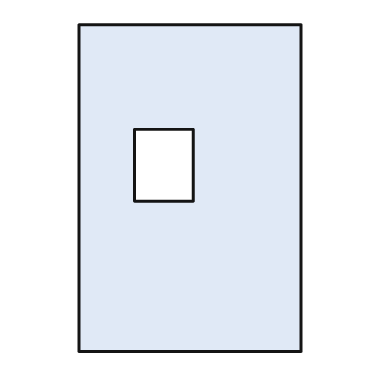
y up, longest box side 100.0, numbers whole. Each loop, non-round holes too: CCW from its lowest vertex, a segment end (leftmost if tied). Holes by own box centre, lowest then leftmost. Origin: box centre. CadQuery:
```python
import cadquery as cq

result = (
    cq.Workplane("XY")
    .moveTo(-34.0, -50.0)
    .lineTo(34.0, -50.0)
    .lineTo(34.0, 50.0)
    .lineTo(-34.0, 50.0)
    .close()
    .moveTo(-17.0, -4.0)
    .lineTo(1.0, -4.0)
    .lineTo(1.0, 18.0)
    .lineTo(-17.0, 18.0)
    .close()
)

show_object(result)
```